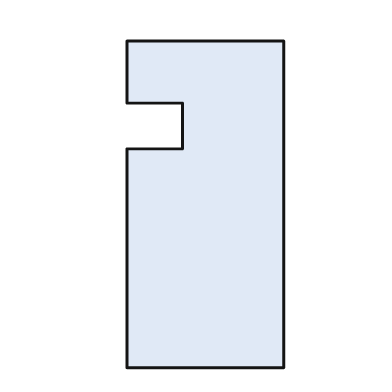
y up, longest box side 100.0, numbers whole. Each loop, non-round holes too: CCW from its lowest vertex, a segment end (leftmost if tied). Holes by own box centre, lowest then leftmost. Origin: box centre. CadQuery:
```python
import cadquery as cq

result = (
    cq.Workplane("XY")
    .moveTo(-24.0, -50.0)
    .lineTo(24.0, -50.0)
    .lineTo(24.0, 50.0)
    .lineTo(-24.0, 50.0)
    .lineTo(-24.0, 31.0)
    .lineTo(-7.0, 31.0)
    .lineTo(-7.0, 17.0)
    .lineTo(-24.0, 17.0)
    .close()
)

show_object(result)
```